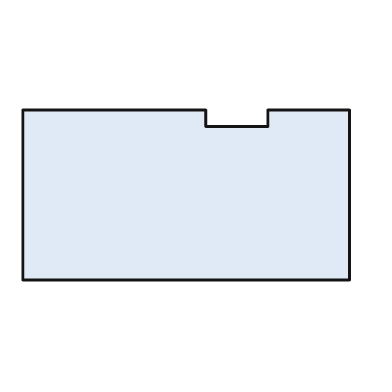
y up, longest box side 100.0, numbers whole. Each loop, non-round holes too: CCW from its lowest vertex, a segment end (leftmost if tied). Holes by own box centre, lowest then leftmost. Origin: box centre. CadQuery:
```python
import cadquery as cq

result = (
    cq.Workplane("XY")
    .moveTo(-50.0, -26.0)
    .lineTo(50.0, -26.0)
    .lineTo(50.0, 26.0)
    .lineTo(25.0, 26.0)
    .lineTo(25.0, 21.0)
    .lineTo(6.0, 21.0)
    .lineTo(6.0, 26.0)
    .lineTo(-50.0, 26.0)
    .close()
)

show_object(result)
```